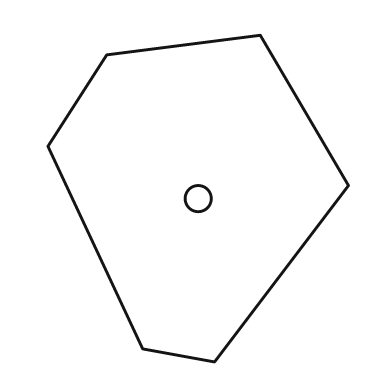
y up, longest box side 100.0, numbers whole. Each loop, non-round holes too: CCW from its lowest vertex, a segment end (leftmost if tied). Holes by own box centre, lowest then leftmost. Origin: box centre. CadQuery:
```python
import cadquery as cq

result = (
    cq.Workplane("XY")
    .moveTo(5.0, -50.0)
    .lineTo(46.0, 4.0)
    .lineTo(19.0, 50.0)
    .lineTo(-28.0, 44.0)
    .lineTo(-46.0, 16.0)
    .lineTo(-17.0, -46.0)
    .close()
    .moveTo(0.0, 0.0)
    .circle(4.0)
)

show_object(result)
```